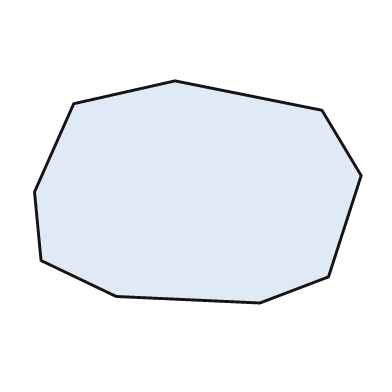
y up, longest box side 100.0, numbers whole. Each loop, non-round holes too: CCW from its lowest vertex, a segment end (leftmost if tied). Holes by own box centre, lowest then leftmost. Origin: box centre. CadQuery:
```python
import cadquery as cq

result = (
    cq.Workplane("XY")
    .moveTo(19.0, -34.0)
    .lineTo(40.0, -26.0)
    .lineTo(50.0, 5.0)
    .lineTo(38.0, 25.0)
    .lineTo(-7.0, 34.0)
    .lineTo(-38.0, 27.0)
    .lineTo(-50.0, 0.0)
    .lineTo(-48.0, -21.0)
    .lineTo(-25.0, -32.0)
    .close()
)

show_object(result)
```